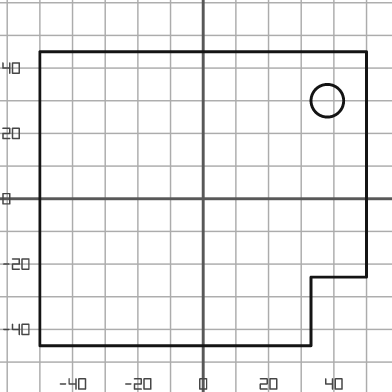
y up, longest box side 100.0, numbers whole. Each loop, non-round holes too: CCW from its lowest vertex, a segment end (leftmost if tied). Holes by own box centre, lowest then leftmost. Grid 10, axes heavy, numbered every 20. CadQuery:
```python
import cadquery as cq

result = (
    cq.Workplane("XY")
    .moveTo(-50.0, -45.0)
    .lineTo(33.0, -45.0)
    .lineTo(33.0, -24.0)
    .lineTo(50.0, -24.0)
    .lineTo(50.0, 45.0)
    .lineTo(-50.0, 45.0)
    .close()
    .moveTo(38.0, 30.0)
    .circle(5.0)
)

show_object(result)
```